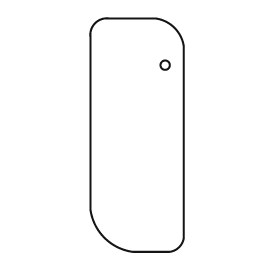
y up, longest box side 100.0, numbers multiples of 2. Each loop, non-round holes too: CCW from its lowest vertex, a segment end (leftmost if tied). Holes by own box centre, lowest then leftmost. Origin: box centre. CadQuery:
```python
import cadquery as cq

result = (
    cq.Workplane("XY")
    .moveTo(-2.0, -50.0)
    .lineTo(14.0, -50.0)
    .threePointArc((18.0, -48.0), (20.0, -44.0))
    .lineTo(20.0, 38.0)
    .threePointArc((16.0, 46.0), (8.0, 50.0))
    .lineTo(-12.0, 50.0)
    .threePointArc((-18.0, 48.0), (-20.0, 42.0))
    .lineTo(-20.0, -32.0)
    .threePointArc((-14.0, -44.0), (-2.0, -50.0))
    .close()
    .moveTo(12.0, 30.0)
    .circle(2.0)
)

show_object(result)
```